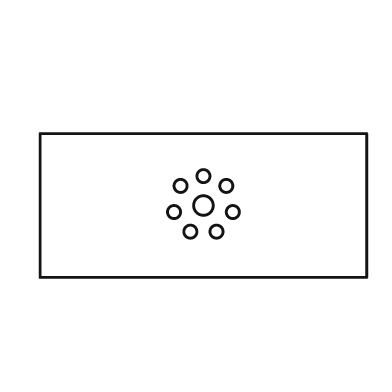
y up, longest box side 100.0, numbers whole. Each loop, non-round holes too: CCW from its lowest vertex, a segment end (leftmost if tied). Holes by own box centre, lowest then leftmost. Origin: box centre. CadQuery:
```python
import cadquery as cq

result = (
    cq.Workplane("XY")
    .moveTo(-50.0, -22.0)
    .lineTo(50.0, -22.0)
    .lineTo(50.0, 22.0)
    .lineTo(-50.0, 22.0)
    .close()
    .moveTo(-4.0, -8.0)
    .circle(2.0)
    .moveTo(4.0, -8.0)
    .circle(2.0)
    .moveTo(-9.0, -2.0)
    .circle(2.0)
    .moveTo(9.0, -2.0)
    .circle(2.0)
    .moveTo(0.0, 0.0)
    .circle(3.0)
    .moveTo(-7.0, 6.0)
    .circle(2.0)
    .moveTo(7.0, 6.0)
    .circle(2.0)
    .moveTo(0.0, 9.0)
    .circle(2.0)
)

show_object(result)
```